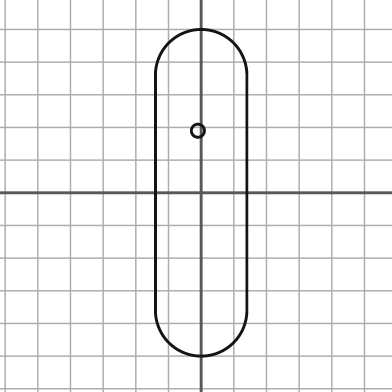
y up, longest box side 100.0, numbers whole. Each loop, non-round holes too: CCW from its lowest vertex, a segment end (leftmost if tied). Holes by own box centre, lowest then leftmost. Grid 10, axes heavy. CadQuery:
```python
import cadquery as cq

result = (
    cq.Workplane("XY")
    .moveTo(-14.0, -36.0)
    .threePointArc((0.0, -50.0), (14.0, -36.0))
    .lineTo(14.0, 36.0)
    .threePointArc((0.0, 50.0), (-14.0, 36.0))
    .close()
    .moveTo(-1.0, 19.0)
    .circle(2.0)
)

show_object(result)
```